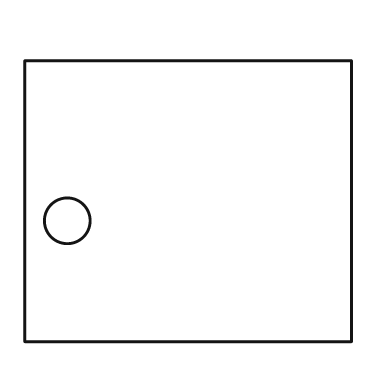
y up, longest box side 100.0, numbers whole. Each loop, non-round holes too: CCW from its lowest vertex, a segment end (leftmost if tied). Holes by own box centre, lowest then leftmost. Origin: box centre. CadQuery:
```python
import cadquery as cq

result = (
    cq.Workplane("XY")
    .moveTo(-50.0, -43.0)
    .lineTo(50.0, -43.0)
    .lineTo(50.0, 43.0)
    .lineTo(-50.0, 43.0)
    .close()
    .moveTo(-37.0, -6.0)
    .circle(7.0)
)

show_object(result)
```